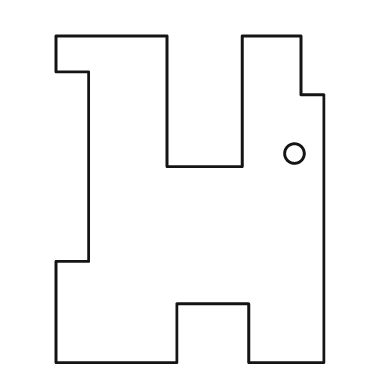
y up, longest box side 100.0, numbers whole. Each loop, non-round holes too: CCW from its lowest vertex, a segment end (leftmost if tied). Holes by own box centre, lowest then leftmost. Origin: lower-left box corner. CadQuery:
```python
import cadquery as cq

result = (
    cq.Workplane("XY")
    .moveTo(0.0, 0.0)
    .lineTo(37.0, 0.0)
    .lineTo(37.0, 18.0)
    .lineTo(59.0, 18.0)
    .lineTo(59.0, 0.0)
    .lineTo(82.0, 0.0)
    .lineTo(82.0, 82.0)
    .lineTo(75.0, 82.0)
    .lineTo(75.0, 100.0)
    .lineTo(57.0, 100.0)
    .lineTo(57.0, 60.0)
    .lineTo(34.0, 60.0)
    .lineTo(34.0, 100.0)
    .lineTo(0.0, 100.0)
    .lineTo(0.0, 89.0)
    .lineTo(10.0, 89.0)
    .lineTo(10.0, 31.0)
    .lineTo(0.0, 31.0)
    .close()
    .moveTo(73.0, 64.0)
    .circle(3.0)
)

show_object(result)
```